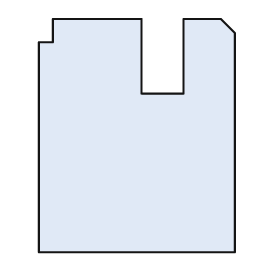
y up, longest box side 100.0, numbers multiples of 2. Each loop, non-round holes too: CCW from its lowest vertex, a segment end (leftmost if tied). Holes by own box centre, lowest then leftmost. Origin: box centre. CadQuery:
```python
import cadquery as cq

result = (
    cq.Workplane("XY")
    .moveTo(-42.0, -50.0)
    .lineTo(42.0, -50.0)
    .lineTo(42.0, 44.0)
    .lineTo(36.0, 50.0)
    .lineTo(20.0, 50.0)
    .lineTo(20.0, 18.0)
    .lineTo(2.0, 18.0)
    .lineTo(2.0, 50.0)
    .lineTo(-36.0, 50.0)
    .lineTo(-36.0, 40.0)
    .lineTo(-42.0, 40.0)
    .close()
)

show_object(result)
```